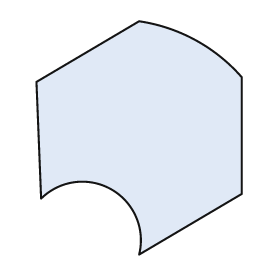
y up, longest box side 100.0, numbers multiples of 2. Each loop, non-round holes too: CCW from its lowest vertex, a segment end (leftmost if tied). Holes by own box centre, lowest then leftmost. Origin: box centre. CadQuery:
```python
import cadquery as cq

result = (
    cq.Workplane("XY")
    .moveTo(0.0, -50.0)
    .lineTo(44.0, -24.0)
    .lineTo(44.0, 26.0)
    .threePointArc((24.0, 42.0), (0.0, 50.0))
    .lineTo(-44.0, 24.0)
    .lineTo(-42.0, -26.0)
    .threePointArc((-12.0, -22.0), (0.0, -50.0))
    .close()
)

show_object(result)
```